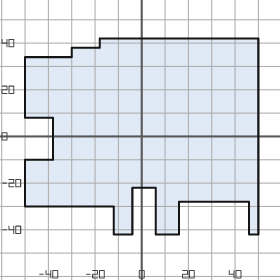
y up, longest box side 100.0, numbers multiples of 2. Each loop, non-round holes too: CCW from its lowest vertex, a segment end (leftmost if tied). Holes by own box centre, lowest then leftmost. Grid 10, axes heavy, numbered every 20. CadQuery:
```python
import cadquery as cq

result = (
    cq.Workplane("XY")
    .moveTo(-12.0, -42.0)
    .lineTo(-4.0, -42.0)
    .lineTo(-4.0, -22.0)
    .lineTo(6.0, -22.0)
    .lineTo(6.0, -42.0)
    .lineTo(16.0, -42.0)
    .lineTo(16.0, -28.0)
    .lineTo(46.0, -28.0)
    .lineTo(46.0, -42.0)
    .lineTo(50.0, -42.0)
    .lineTo(50.0, 42.0)
    .lineTo(-18.0, 42.0)
    .lineTo(-18.0, 38.0)
    .lineTo(-30.0, 38.0)
    .lineTo(-30.0, 34.0)
    .lineTo(-50.0, 34.0)
    .lineTo(-50.0, 8.0)
    .lineTo(-38.0, 8.0)
    .lineTo(-38.0, -10.0)
    .lineTo(-50.0, -10.0)
    .lineTo(-50.0, -30.0)
    .lineTo(-12.0, -30.0)
    .close()
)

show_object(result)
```